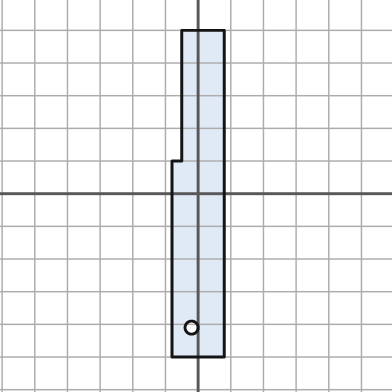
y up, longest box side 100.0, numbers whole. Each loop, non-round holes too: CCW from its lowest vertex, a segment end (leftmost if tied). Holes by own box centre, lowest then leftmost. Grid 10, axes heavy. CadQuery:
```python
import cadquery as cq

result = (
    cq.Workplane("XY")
    .moveTo(-8.0, -50.0)
    .lineTo(8.0, -50.0)
    .lineTo(8.0, 50.0)
    .lineTo(-5.0, 50.0)
    .lineTo(-5.0, 10.0)
    .lineTo(-8.0, 10.0)
    .close()
    .moveTo(-2.0, -41.0)
    .circle(2.0)
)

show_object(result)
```